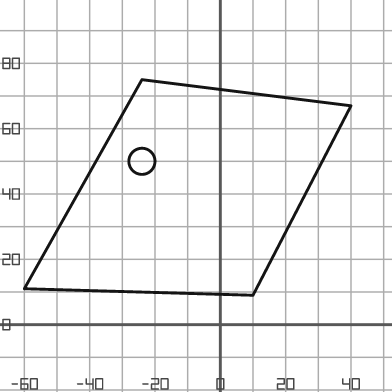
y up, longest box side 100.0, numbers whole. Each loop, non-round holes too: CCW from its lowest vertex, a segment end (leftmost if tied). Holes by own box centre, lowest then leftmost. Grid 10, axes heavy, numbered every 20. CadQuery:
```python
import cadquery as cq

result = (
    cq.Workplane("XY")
    .moveTo(10.0, 9.0)
    .lineTo(40.0, 67.0)
    .lineTo(-24.0, 75.0)
    .lineTo(-60.0, 11.0)
    .close()
    .moveTo(-24.0, 50.0)
    .circle(4.0)
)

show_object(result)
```